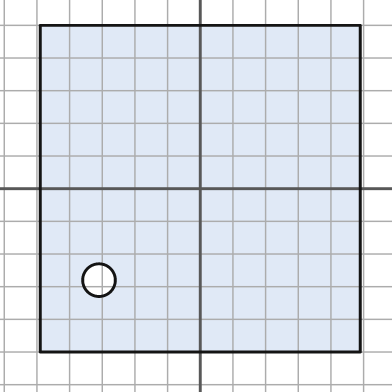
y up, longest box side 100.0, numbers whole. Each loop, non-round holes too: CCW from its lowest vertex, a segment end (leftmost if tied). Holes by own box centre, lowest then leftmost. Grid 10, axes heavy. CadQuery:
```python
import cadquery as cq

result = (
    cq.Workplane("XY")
    .moveTo(-49.0, -50.0)
    .lineTo(49.0, -50.0)
    .lineTo(49.0, 50.0)
    .lineTo(-49.0, 50.0)
    .close()
    .moveTo(-31.0, -28.0)
    .circle(5.0)
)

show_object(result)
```